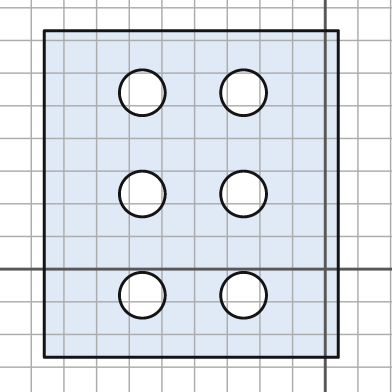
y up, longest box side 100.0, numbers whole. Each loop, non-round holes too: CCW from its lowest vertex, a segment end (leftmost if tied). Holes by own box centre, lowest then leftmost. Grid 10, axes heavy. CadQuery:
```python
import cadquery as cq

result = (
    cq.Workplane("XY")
    .moveTo(-86.0, -27.0)
    .lineTo(4.0, -27.0)
    .lineTo(4.0, 73.0)
    .lineTo(-86.0, 73.0)
    .close()
    .moveTo(-56.0, -8.0)
    .circle(7.0)
    .moveTo(-25.0, -8.0)
    .circle(7.0)
    .moveTo(-56.0, 23.0)
    .circle(7.0)
    .moveTo(-25.0, 23.0)
    .circle(7.0)
    .moveTo(-56.0, 54.0)
    .circle(7.0)
    .moveTo(-25.0, 54.0)
    .circle(7.0)
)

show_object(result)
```